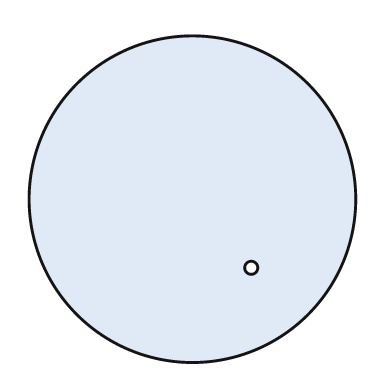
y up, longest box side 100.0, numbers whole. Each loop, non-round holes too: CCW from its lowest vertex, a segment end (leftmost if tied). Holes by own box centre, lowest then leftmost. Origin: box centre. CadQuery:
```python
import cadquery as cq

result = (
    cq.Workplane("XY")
    .moveTo(0.0, 0.0)
    .circle(50.0)
    .moveTo(18.0, -21.0)
    .circle(2.0)
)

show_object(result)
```